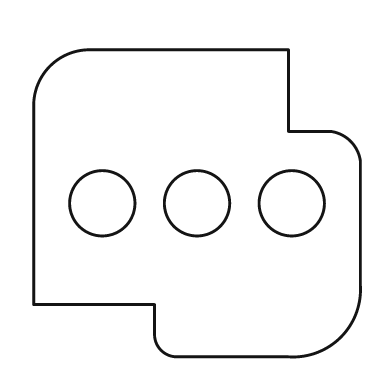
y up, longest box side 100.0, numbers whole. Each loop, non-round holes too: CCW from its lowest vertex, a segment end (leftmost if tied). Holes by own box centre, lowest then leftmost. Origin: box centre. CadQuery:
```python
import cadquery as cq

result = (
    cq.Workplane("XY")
    .moveTo(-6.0, -47.0)
    .lineTo(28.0, -47.0)
    .threePointArc((44.0, -41.0), (50.0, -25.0))
    .lineTo(50.0, 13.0)
    .threePointArc((47.0, 19.0), (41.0, 22.0))
    .lineTo(28.0, 22.0)
    .lineTo(28.0, 47.0)
    .lineTo(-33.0, 47.0)
    .threePointArc((-45.0, 42.0), (-50.0, 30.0))
    .lineTo(-50.0, -31.0)
    .lineTo(-13.0, -31.0)
    .lineTo(-13.0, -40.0)
    .threePointArc((-11.0, -45.0), (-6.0, -47.0))
    .close()
    .moveTo(-29.0, 0.0)
    .circle(10.0)
    .moveTo(0.0, 0.0)
    .circle(10.0)
    .moveTo(29.0, 0.0)
    .circle(10.0)
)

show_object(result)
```